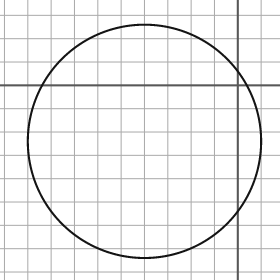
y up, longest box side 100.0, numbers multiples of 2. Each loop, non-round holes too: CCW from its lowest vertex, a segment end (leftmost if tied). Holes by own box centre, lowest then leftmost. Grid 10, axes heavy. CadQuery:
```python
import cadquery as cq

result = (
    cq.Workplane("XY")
    .moveTo(-40.0, -24.0)
    .circle(50.0)
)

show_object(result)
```